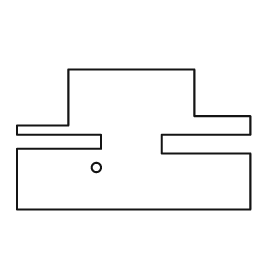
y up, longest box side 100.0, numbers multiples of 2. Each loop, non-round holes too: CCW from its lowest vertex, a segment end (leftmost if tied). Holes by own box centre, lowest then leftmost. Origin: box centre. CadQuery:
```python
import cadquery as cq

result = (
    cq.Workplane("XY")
    .moveTo(-50.0, -30.0)
    .lineTo(50.0, -30.0)
    .lineTo(50.0, -6.0)
    .lineTo(12.0, -6.0)
    .lineTo(12.0, 2.0)
    .lineTo(50.0, 2.0)
    .lineTo(50.0, 10.0)
    .lineTo(26.0, 10.0)
    .lineTo(26.0, 30.0)
    .lineTo(-28.0, 30.0)
    .lineTo(-28.0, 6.0)
    .lineTo(-50.0, 6.0)
    .lineTo(-50.0, 2.0)
    .lineTo(-14.0, 2.0)
    .lineTo(-14.0, -4.0)
    .lineTo(-50.0, -4.0)
    .close()
    .moveTo(-16.0, -12.0)
    .circle(2.0)
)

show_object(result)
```